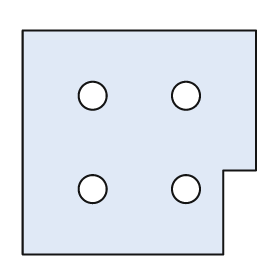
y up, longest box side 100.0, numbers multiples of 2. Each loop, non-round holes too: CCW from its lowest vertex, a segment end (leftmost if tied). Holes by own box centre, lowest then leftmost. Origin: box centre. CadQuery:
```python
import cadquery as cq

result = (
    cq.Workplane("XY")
    .moveTo(-50.0, -48.0)
    .lineTo(36.0, -48.0)
    .lineTo(36.0, -12.0)
    .lineTo(50.0, -12.0)
    .lineTo(50.0, 48.0)
    .lineTo(-50.0, 48.0)
    .close()
    .moveTo(-20.0, -20.0)
    .circle(6.0)
    .moveTo(20.0, -20.0)
    .circle(6.0)
    .moveTo(-20.0, 20.0)
    .circle(6.0)
    .moveTo(20.0, 20.0)
    .circle(6.0)
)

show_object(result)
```